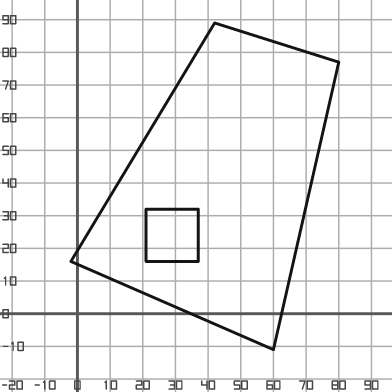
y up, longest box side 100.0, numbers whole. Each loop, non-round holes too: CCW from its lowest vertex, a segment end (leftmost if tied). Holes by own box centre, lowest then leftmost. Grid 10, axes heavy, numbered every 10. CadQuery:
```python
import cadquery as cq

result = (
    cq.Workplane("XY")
    .moveTo(60.0, -11.0)
    .lineTo(80.0, 77.0)
    .lineTo(42.0, 89.0)
    .lineTo(-2.0, 16.0)
    .close()
    .moveTo(21.0, 16.0)
    .lineTo(37.0, 16.0)
    .lineTo(37.0, 32.0)
    .lineTo(21.0, 32.0)
    .close()
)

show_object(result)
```